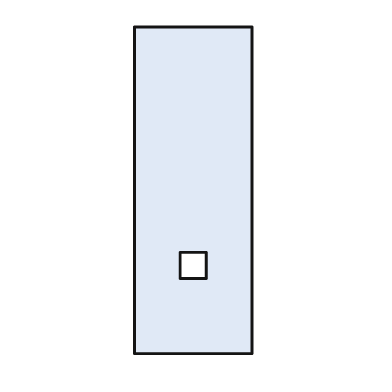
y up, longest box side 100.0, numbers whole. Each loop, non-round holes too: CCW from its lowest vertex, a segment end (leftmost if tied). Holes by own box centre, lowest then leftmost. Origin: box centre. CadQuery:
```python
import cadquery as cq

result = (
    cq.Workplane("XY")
    .moveTo(-18.0, -50.0)
    .lineTo(18.0, -50.0)
    .lineTo(18.0, 50.0)
    .lineTo(-18.0, 50.0)
    .close()
    .moveTo(-4.0, -27.0)
    .lineTo(4.0, -27.0)
    .lineTo(4.0, -19.0)
    .lineTo(-4.0, -19.0)
    .close()
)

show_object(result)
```